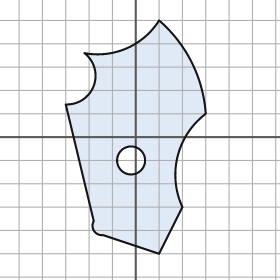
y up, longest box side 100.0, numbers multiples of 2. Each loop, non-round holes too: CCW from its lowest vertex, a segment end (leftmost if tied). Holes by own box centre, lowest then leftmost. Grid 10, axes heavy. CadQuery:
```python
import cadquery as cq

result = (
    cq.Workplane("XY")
    .moveTo(10.0, -50.0)
    .lineTo(20.0, -30.0)
    .threePointArc((18.0, -8.0), (30.0, 10.0))
    .threePointArc((24.0, 32.0), (10.0, 50.0))
    .threePointArc((-4.0, 38.0), (-22.0, 36.0))
    .threePointArc((-18.0, 22.0), (-30.0, 14.0))
    .lineTo(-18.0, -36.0)
    .threePointArc((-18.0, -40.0), (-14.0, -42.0))
    .close()
    .moveTo(-2.0, -10.0)
    .circle(6.0)
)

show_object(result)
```